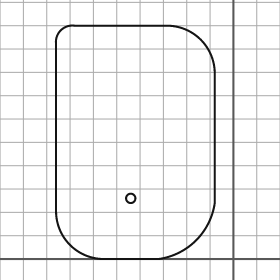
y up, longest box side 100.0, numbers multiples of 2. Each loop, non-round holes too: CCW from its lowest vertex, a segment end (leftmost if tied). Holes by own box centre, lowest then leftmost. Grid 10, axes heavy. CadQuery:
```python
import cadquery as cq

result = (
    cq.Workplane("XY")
    .moveTo(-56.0, 0.0)
    .lineTo(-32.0, 0.0)
    .threePointArc((-16.0, 8.0), (-8.0, 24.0))
    .lineTo(-8.0, 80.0)
    .threePointArc((-14.0, 94.0), (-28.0, 100.0))
    .lineTo(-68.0, 100.0)
    .threePointArc((-74.0, 98.0), (-76.0, 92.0))
    .lineTo(-76.0, 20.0)
    .threePointArc((-70.0, 6.0), (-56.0, 0.0))
    .close()
    .moveTo(-44.0, 26.0)
    .circle(2.0)
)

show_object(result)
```